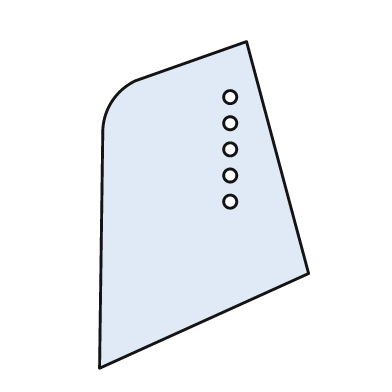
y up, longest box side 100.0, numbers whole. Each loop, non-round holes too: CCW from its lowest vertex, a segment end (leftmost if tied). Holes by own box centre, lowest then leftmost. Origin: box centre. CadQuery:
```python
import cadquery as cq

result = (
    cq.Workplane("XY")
    .moveTo(-32.0, -50.0)
    .lineTo(32.0, -21.0)
    .lineTo(13.0, 50.0)
    .lineTo(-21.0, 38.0)
    .threePointArc((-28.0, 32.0), (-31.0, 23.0))
    .close()
    .moveTo(8.0, 1.0)
    .circle(2.0)
    .moveTo(8.0, 9.0)
    .circle(2.0)
    .moveTo(8.0, 17.0)
    .circle(2.0)
    .moveTo(8.0, 25.0)
    .circle(2.0)
    .moveTo(8.0, 33.0)
    .circle(2.0)
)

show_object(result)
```